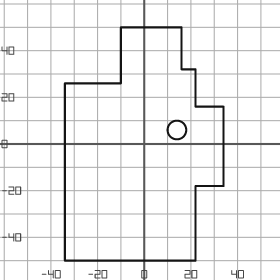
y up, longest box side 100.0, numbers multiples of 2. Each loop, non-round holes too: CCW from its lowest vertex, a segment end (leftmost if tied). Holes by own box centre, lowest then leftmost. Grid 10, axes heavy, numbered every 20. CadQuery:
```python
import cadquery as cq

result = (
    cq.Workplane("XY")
    .moveTo(-34.0, -50.0)
    .lineTo(22.0, -50.0)
    .lineTo(22.0, -18.0)
    .lineTo(34.0, -18.0)
    .lineTo(34.0, 16.0)
    .lineTo(22.0, 16.0)
    .lineTo(22.0, 32.0)
    .lineTo(16.0, 32.0)
    .lineTo(16.0, 50.0)
    .lineTo(-10.0, 50.0)
    .lineTo(-10.0, 26.0)
    .lineTo(-34.0, 26.0)
    .close()
    .moveTo(14.0, 6.0)
    .circle(4.0)
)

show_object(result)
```